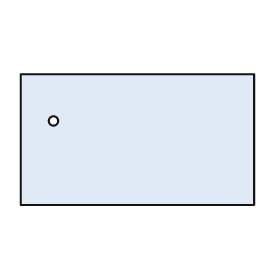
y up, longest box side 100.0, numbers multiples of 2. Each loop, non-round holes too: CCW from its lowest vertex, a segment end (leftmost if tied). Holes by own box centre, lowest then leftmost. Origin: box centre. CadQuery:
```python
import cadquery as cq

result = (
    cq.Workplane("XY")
    .moveTo(-50.0, -28.0)
    .lineTo(50.0, -28.0)
    .lineTo(50.0, 28.0)
    .lineTo(-50.0, 28.0)
    .close()
    .moveTo(-36.0, 8.0)
    .circle(2.0)
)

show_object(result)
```